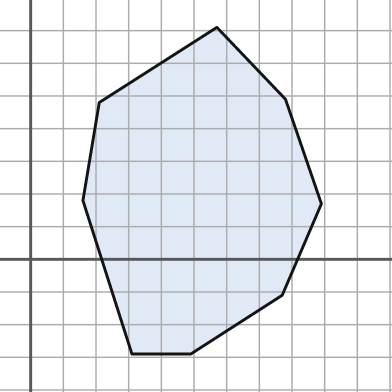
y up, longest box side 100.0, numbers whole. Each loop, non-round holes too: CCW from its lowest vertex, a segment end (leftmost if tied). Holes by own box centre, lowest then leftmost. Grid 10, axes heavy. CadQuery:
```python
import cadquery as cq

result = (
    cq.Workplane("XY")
    .moveTo(31.0, -29.0)
    .lineTo(49.0, -29.0)
    .lineTo(77.0, -11.0)
    .lineTo(89.0, 17.0)
    .lineTo(78.0, 49.0)
    .lineTo(57.0, 71.0)
    .lineTo(21.0, 48.0)
    .lineTo(16.0, 18.0)
    .close()
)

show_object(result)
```